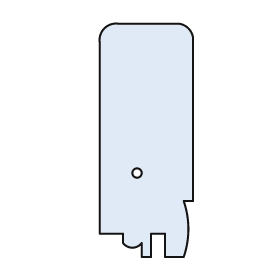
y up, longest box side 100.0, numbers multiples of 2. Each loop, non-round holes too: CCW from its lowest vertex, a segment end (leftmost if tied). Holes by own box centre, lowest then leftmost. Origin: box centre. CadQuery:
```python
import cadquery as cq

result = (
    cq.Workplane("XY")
    .moveTo(-2.0, -50.0)
    .lineTo(2.0, -50.0)
    .lineTo(2.0, -40.0)
    .lineTo(8.0, -40.0)
    .lineTo(8.0, -50.0)
    .lineTo(16.0, -50.0)
    .threePointArc((18.0, -38.0), (16.0, -26.0))
    .lineTo(20.0, -26.0)
    .lineTo(20.0, 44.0)
    .threePointArc((18.0, 48.0), (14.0, 50.0))
    .lineTo(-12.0, 50.0)
    .threePointArc((-18.0, 48.0), (-20.0, 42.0))
    .lineTo(-20.0, -40.0)
    .lineTo(-10.0, -40.0)
    .lineTo(-10.0, -44.0)
    .threePointArc((-6.0, -46.0), (-2.0, -44.0))
    .close()
    .moveTo(-4.0, -14.0)
    .circle(2.0)
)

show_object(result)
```